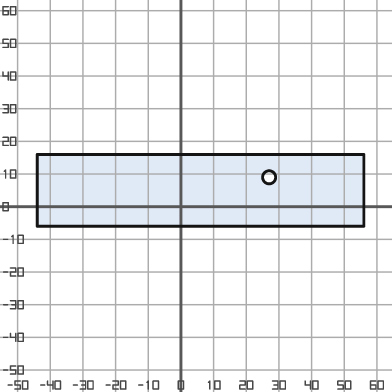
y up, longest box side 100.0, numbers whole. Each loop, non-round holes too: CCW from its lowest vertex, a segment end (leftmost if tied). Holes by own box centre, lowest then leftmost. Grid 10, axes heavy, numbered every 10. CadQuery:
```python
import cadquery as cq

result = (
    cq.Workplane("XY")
    .moveTo(-44.0, -6.0)
    .lineTo(56.0, -6.0)
    .lineTo(56.0, 16.0)
    .lineTo(-44.0, 16.0)
    .close()
    .moveTo(27.0, 9.0)
    .circle(2.0)
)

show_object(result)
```